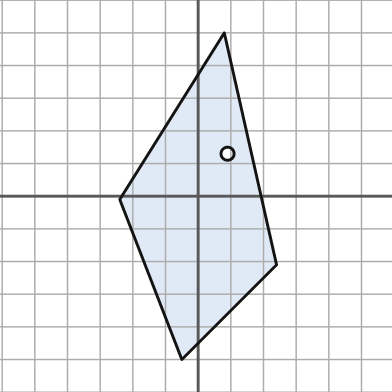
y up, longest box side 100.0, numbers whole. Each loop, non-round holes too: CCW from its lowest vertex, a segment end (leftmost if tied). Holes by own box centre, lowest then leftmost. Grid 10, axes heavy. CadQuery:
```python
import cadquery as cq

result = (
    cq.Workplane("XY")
    .moveTo(-5.0, -50.0)
    .lineTo(24.0, -21.0)
    .lineTo(8.0, 50.0)
    .lineTo(-24.0, -1.0)
    .close()
    .moveTo(9.0, 13.0)
    .circle(2.0)
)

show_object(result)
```